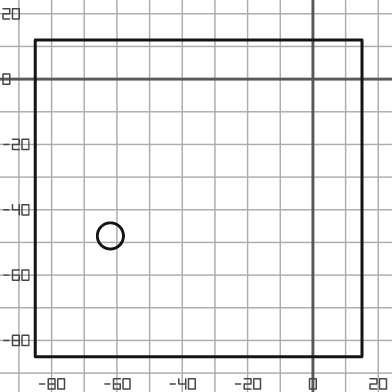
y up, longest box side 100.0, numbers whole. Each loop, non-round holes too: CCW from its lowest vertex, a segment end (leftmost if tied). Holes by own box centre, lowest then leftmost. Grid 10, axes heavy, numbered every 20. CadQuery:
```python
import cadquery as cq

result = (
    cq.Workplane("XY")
    .moveTo(-85.0, -85.0)
    .lineTo(15.0, -85.0)
    .lineTo(15.0, 12.0)
    .lineTo(-85.0, 12.0)
    .close()
    .moveTo(-62.0, -48.0)
    .circle(4.0)
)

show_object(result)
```